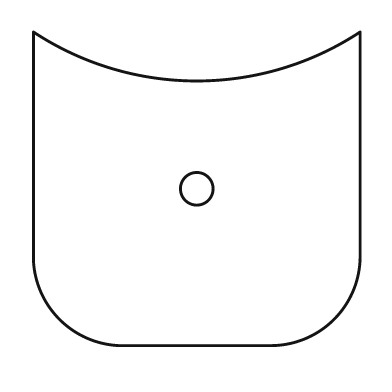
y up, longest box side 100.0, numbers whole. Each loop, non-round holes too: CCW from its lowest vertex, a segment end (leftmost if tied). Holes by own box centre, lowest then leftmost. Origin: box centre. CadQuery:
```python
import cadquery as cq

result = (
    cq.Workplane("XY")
    .moveTo(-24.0, -48.0)
    .lineTo(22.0, -48.0)
    .threePointArc((42.0, -40.0), (50.0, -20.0))
    .lineTo(50.0, 48.0)
    .threePointArc((0.0, 33.0), (-50.0, 48.0))
    .lineTo(-50.0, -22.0)
    .threePointArc((-42.0, -40.0), (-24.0, -48.0))
    .close()
    .moveTo(0.0, 0.0)
    .circle(5.0)
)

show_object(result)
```